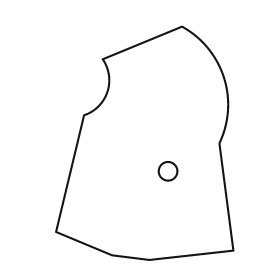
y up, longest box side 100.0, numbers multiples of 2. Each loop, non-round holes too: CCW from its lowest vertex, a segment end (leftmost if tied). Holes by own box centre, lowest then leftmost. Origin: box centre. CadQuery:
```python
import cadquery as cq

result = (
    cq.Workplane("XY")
    .moveTo(2.0, -50.0)
    .lineTo(38.0, -46.0)
    .lineTo(32.0, 0.0)
    .threePointArc((34.0, 28.0), (16.0, 50.0))
    .lineTo(-18.0, 36.0)
    .threePointArc((-16.0, 22.0), (-26.0, 12.0))
    .lineTo(-38.0, -38.0)
    .lineTo(-14.0, -48.0)
    .close()
    .moveTo(10.0, -12.0)
    .circle(4.0)
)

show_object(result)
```